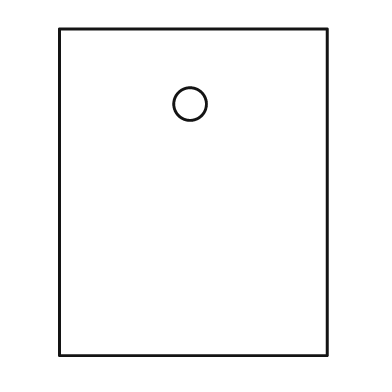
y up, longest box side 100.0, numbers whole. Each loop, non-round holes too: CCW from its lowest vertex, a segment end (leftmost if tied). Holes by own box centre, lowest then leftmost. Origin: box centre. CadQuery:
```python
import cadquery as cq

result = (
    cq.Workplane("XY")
    .moveTo(-41.0, -50.0)
    .lineTo(41.0, -50.0)
    .lineTo(41.0, 50.0)
    .lineTo(-41.0, 50.0)
    .close()
    .moveTo(-1.0, 27.0)
    .circle(5.0)
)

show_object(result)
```